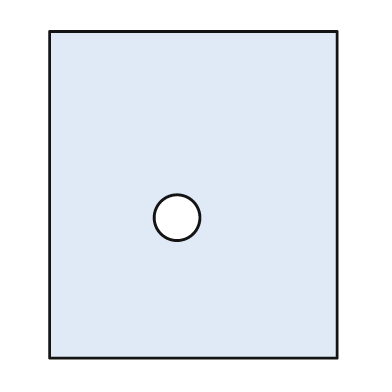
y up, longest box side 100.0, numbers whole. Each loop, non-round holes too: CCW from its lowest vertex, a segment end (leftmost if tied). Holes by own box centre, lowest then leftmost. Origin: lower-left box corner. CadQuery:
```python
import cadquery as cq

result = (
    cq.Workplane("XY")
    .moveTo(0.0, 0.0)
    .lineTo(88.0, 0.0)
    .lineTo(88.0, 100.0)
    .lineTo(0.0, 100.0)
    .close()
    .moveTo(39.0, 43.0)
    .circle(7.0)
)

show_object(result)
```